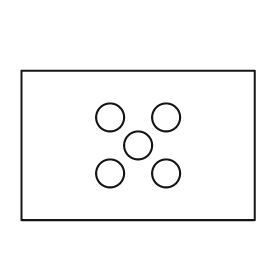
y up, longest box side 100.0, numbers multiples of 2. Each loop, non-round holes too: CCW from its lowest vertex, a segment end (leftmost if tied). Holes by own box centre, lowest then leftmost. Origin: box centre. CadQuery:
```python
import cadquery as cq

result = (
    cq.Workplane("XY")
    .moveTo(-50.0, -32.0)
    .lineTo(50.0, -32.0)
    .lineTo(50.0, 32.0)
    .lineTo(-50.0, 32.0)
    .close()
    .moveTo(-12.0, -12.0)
    .circle(6.0)
    .moveTo(12.0, -12.0)
    .circle(6.0)
    .moveTo(0.0, 0.0)
    .circle(6.0)
    .moveTo(-12.0, 12.0)
    .circle(6.0)
    .moveTo(12.0, 12.0)
    .circle(6.0)
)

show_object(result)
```